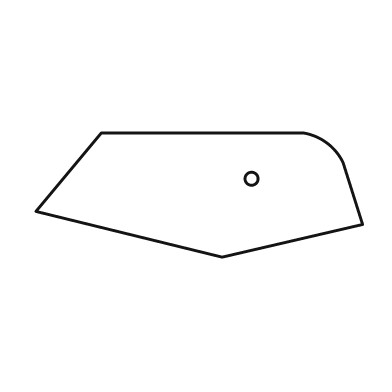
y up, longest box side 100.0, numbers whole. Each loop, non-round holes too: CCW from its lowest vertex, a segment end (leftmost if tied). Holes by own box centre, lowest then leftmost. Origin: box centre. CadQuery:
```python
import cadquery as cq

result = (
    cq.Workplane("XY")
    .moveTo(7.0, -19.0)
    .lineTo(50.0, -9.0)
    .lineTo(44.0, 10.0)
    .threePointArc((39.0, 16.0), (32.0, 19.0))
    .lineTo(-30.0, 19.0)
    .lineTo(-50.0, -5.0)
    .close()
    .moveTo(16.0, 5.0)
    .circle(2.0)
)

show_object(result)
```